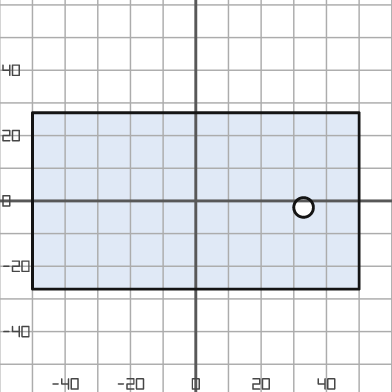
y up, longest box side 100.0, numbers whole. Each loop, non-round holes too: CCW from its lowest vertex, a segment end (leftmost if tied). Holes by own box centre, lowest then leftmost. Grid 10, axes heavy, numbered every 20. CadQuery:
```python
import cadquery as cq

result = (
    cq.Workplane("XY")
    .moveTo(-50.0, -27.0)
    .lineTo(50.0, -27.0)
    .lineTo(50.0, 27.0)
    .lineTo(-50.0, 27.0)
    .close()
    .moveTo(33.0, -2.0)
    .circle(3.0)
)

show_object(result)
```